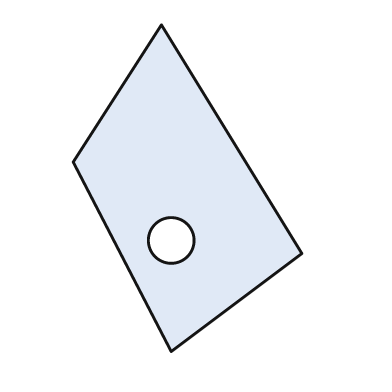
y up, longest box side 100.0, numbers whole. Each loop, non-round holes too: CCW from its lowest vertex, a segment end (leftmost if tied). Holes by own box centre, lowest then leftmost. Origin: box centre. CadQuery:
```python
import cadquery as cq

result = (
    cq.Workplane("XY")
    .moveTo(-5.0, -50.0)
    .lineTo(35.0, -20.0)
    .lineTo(-8.0, 50.0)
    .lineTo(-35.0, 8.0)
    .close()
    .moveTo(-5.0, -16.0)
    .circle(7.0)
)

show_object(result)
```